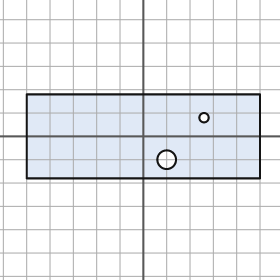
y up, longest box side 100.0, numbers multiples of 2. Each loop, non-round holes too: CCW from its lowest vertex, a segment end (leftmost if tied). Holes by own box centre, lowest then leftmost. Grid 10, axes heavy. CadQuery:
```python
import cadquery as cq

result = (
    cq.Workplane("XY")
    .moveTo(-50.0, -18.0)
    .lineTo(50.0, -18.0)
    .lineTo(50.0, 18.0)
    .lineTo(-50.0, 18.0)
    .close()
    .moveTo(10.0, -10.0)
    .circle(4.0)
    .moveTo(26.0, 8.0)
    .circle(2.0)
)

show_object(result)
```